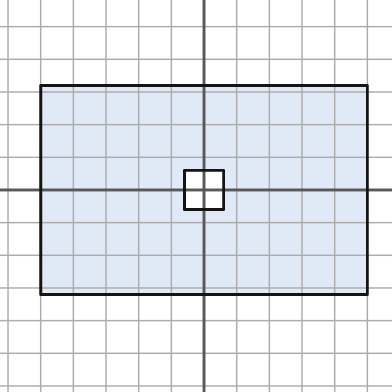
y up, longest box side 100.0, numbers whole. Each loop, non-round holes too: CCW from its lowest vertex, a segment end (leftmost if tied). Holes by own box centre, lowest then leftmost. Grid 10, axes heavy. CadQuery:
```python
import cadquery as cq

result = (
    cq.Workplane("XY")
    .moveTo(-50.0, -32.0)
    .lineTo(50.0, -32.0)
    .lineTo(50.0, 32.0)
    .lineTo(-50.0, 32.0)
    .close()
    .moveTo(-6.0, -6.0)
    .lineTo(6.0, -6.0)
    .lineTo(6.0, 6.0)
    .lineTo(-6.0, 6.0)
    .close()
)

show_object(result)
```